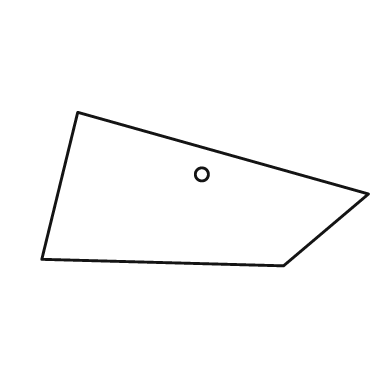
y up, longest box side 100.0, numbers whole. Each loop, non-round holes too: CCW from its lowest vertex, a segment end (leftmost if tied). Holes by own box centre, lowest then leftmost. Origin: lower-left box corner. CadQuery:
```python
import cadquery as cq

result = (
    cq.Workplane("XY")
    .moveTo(74.0, 0.0)
    .lineTo(100.0, 22.0)
    .lineTo(11.0, 47.0)
    .lineTo(0.0, 2.0)
    .close()
    .moveTo(49.0, 28.0)
    .circle(2.0)
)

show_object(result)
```